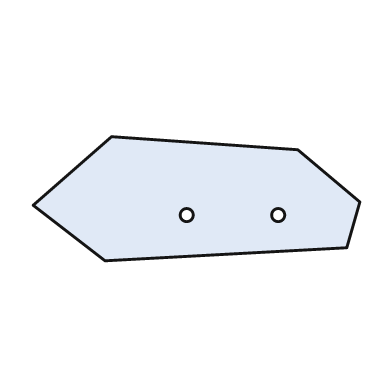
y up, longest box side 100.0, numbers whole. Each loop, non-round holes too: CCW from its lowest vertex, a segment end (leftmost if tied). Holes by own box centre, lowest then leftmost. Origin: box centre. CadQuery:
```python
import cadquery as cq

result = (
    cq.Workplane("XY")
    .moveTo(-28.0, -19.0)
    .lineTo(46.0, -15.0)
    .lineTo(50.0, -1.0)
    .lineTo(31.0, 15.0)
    .lineTo(-26.0, 19.0)
    .lineTo(-50.0, -2.0)
    .close()
    .moveTo(-3.0, -5.0)
    .circle(2.0)
    .moveTo(25.0, -5.0)
    .circle(2.0)
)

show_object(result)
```